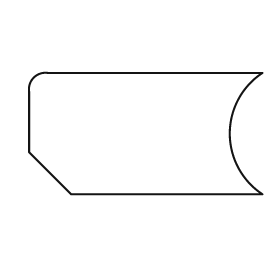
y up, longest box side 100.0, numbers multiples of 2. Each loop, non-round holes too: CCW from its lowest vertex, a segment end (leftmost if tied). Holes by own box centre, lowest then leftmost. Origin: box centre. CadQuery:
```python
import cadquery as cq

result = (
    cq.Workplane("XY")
    .moveTo(-32.0, -26.0)
    .lineTo(50.0, -26.0)
    .threePointArc((36.0, 0.0), (50.0, 26.0))
    .lineTo(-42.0, 26.0)
    .threePointArc((-48.0, 24.0), (-50.0, 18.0))
    .lineTo(-50.0, -8.0)
    .close()
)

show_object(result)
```